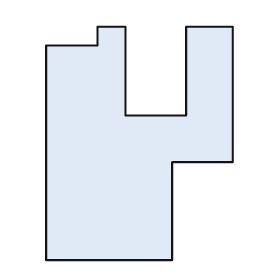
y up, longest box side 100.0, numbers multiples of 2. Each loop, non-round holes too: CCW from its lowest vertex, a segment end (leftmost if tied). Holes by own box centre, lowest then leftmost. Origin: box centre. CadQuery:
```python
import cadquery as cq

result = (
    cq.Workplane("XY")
    .moveTo(-40.0, -50.0)
    .lineTo(14.0, -50.0)
    .lineTo(14.0, -8.0)
    .lineTo(40.0, -8.0)
    .lineTo(40.0, 50.0)
    .lineTo(20.0, 50.0)
    .lineTo(20.0, 12.0)
    .lineTo(-6.0, 12.0)
    .lineTo(-6.0, 50.0)
    .lineTo(-18.0, 50.0)
    .lineTo(-18.0, 42.0)
    .lineTo(-40.0, 42.0)
    .close()
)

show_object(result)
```